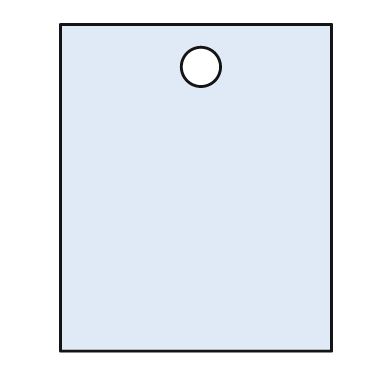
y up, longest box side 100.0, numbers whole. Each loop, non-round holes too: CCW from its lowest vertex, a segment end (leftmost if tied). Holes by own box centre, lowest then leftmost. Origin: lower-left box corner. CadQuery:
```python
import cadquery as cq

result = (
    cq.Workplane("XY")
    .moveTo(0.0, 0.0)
    .lineTo(83.0, 0.0)
    .lineTo(83.0, 100.0)
    .lineTo(0.0, 100.0)
    .close()
    .moveTo(43.0, 87.0)
    .circle(6.0)
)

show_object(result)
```